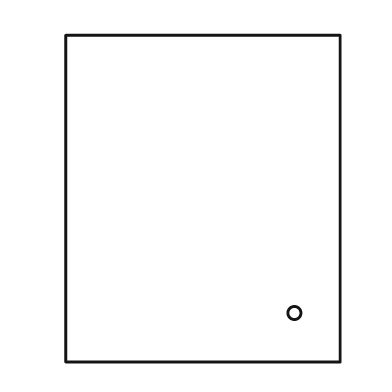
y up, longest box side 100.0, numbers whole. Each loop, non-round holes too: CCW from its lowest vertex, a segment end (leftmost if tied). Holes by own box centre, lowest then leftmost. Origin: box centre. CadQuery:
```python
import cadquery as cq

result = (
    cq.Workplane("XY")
    .moveTo(-42.0, -50.0)
    .lineTo(42.0, -50.0)
    .lineTo(42.0, 50.0)
    .lineTo(-42.0, 50.0)
    .close()
    .moveTo(28.0, -35.0)
    .circle(2.0)
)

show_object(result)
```